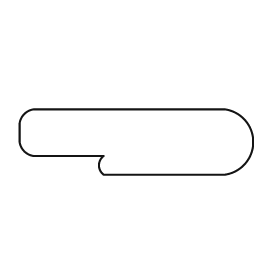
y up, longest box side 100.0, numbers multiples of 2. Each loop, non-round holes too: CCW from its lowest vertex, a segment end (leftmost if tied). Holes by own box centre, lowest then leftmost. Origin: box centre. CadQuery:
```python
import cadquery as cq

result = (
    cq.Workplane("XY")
    .moveTo(-14.0, -14.0)
    .lineTo(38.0, -14.0)
    .threePointArc((46.0, -10.0), (50.0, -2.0))
    .lineTo(50.0, 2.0)
    .threePointArc((46.0, 10.0), (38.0, 14.0))
    .lineTo(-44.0, 14.0)
    .threePointArc((-48.0, 12.0), (-50.0, 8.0))
    .lineTo(-50.0, 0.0)
    .threePointArc((-48.0, -4.0), (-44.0, -6.0))
    .lineTo(-14.0, -6.0)
    .threePointArc((-16.0, -10.0), (-14.0, -14.0))
    .close()
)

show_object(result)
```